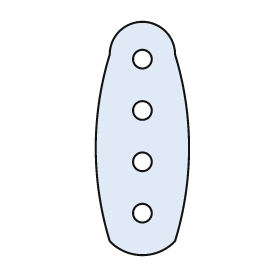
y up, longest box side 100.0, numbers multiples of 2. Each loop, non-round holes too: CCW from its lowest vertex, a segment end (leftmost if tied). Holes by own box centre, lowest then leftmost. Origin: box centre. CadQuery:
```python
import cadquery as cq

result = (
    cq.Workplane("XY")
    .moveTo(-14.0, -44.0)
    .threePointArc((0.0, -50.0), (14.0, -44.0))
    .threePointArc((20.0, -4.0), (14.0, 36.0))
    .threePointArc((0.0, 50.0), (-14.0, 36.0))
    .threePointArc((-20.0, -4.0), (-14.0, -44.0))
    .close()
    .moveTo(0.0, -32.0)
    .circle(4.0)
    .moveTo(0.0, -10.0)
    .circle(4.0)
    .moveTo(0.0, 12.0)
    .circle(4.0)
    .moveTo(0.0, 34.0)
    .circle(4.0)
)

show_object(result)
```